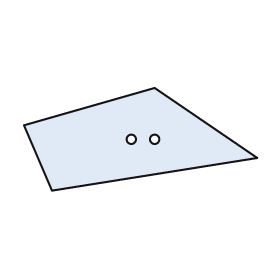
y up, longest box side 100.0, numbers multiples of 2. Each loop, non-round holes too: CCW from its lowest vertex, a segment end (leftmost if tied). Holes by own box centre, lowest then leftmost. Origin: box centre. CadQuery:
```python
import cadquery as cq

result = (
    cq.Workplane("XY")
    .moveTo(-38.0, -22.0)
    .lineTo(50.0, -8.0)
    .lineTo(6.0, 22.0)
    .lineTo(-50.0, 6.0)
    .close()
    .moveTo(-4.0, 0.0)
    .circle(2.0)
    .moveTo(6.0, 0.0)
    .circle(2.0)
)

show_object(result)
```